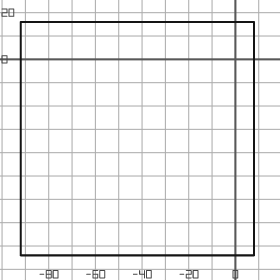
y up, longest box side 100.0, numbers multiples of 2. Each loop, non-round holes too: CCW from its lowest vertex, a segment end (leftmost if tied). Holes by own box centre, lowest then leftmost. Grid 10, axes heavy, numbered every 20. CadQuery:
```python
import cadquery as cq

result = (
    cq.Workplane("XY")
    .moveTo(-92.0, -84.0)
    .lineTo(8.0, -84.0)
    .lineTo(8.0, 16.0)
    .lineTo(-92.0, 16.0)
    .close()
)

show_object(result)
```